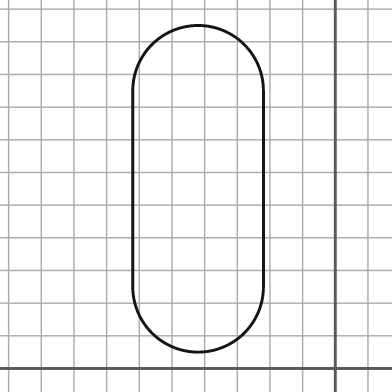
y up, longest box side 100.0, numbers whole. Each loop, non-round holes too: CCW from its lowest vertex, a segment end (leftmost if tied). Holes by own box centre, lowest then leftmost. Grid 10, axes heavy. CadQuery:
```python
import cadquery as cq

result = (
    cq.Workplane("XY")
    .moveTo(-62.0, 25.0)
    .threePointArc((-42.0, 5.0), (-22.0, 25.0))
    .lineTo(-22.0, 85.0)
    .threePointArc((-42.0, 105.0), (-62.0, 85.0))
    .close()
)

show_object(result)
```